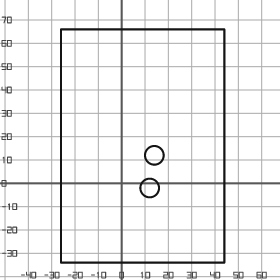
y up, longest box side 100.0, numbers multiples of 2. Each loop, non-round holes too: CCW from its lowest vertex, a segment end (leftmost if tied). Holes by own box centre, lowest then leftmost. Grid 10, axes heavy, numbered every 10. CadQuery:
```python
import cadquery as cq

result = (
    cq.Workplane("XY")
    .moveTo(-26.0, -34.0)
    .lineTo(44.0, -34.0)
    .lineTo(44.0, 66.0)
    .lineTo(-26.0, 66.0)
    .close()
    .moveTo(12.0, -2.0)
    .circle(4.0)
    .moveTo(14.0, 12.0)
    .circle(4.0)
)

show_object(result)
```